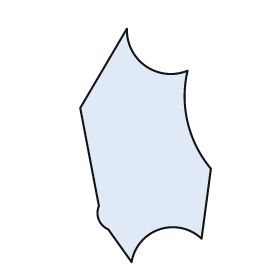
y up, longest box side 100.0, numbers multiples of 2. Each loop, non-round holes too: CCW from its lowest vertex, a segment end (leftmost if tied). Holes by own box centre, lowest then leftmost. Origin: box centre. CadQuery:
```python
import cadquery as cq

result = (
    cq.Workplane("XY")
    .moveTo(-6.0, -50.0)
    .threePointArc((6.0, -36.0), (24.0, -40.0))
    .lineTo(28.0, -10.0)
    .threePointArc((18.0, 10.0), (18.0, 32.0))
    .threePointArc((0.0, 34.0), (-8.0, 50.0))
    .lineTo(-28.0, 16.0)
    .lineTo(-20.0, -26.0)
    .threePointArc((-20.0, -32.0), (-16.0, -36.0))
    .close()
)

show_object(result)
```